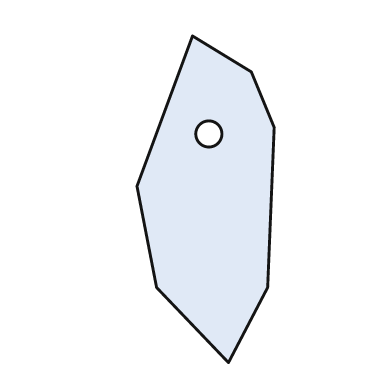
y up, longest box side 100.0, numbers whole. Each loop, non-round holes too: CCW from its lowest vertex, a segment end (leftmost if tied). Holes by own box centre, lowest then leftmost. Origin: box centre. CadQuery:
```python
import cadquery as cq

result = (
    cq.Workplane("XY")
    .moveTo(7.0, -50.0)
    .lineTo(19.0, -27.0)
    .lineTo(21.0, 22.0)
    .lineTo(14.0, 39.0)
    .lineTo(-4.0, 50.0)
    .lineTo(-21.0, 4.0)
    .lineTo(-15.0, -27.0)
    .close()
    .moveTo(1.0, 20.0)
    .circle(4.0)
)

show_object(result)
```